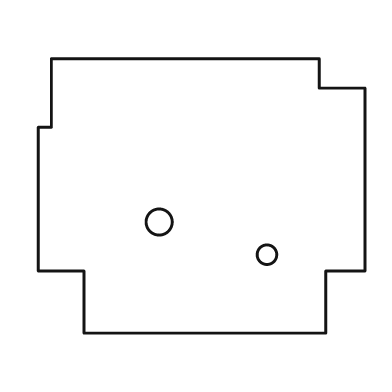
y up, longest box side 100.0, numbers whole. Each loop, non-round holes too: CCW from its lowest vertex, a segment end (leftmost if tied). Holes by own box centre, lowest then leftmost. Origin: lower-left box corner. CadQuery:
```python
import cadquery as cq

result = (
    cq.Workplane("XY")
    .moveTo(14.0, 0.0)
    .lineTo(88.0, 0.0)
    .lineTo(88.0, 19.0)
    .lineTo(100.0, 19.0)
    .lineTo(100.0, 75.0)
    .lineTo(86.0, 75.0)
    .lineTo(86.0, 84.0)
    .lineTo(4.0, 84.0)
    .lineTo(4.0, 63.0)
    .lineTo(0.0, 63.0)
    .lineTo(0.0, 19.0)
    .lineTo(14.0, 19.0)
    .close()
    .moveTo(70.0, 24.0)
    .circle(3.0)
    .moveTo(37.0, 34.0)
    .circle(4.0)
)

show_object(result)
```